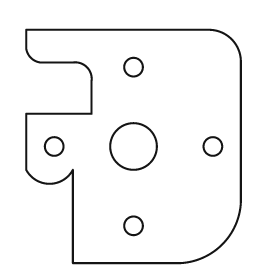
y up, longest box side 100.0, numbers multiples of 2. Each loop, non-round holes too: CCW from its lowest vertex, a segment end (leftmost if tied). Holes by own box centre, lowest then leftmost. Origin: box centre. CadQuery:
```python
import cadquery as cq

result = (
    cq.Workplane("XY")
    .moveTo(-26.0, -50.0)
    .lineTo(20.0, -50.0)
    .threePointArc((38.0, -42.0), (46.0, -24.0))
    .lineTo(46.0, 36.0)
    .threePointArc((42.0, 46.0), (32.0, 50.0))
    .lineTo(-46.0, 50.0)
    .lineTo(-46.0, 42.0)
    .threePointArc((-44.0, 38.0), (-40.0, 36.0))
    .lineTo(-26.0, 36.0)
    .threePointArc((-20.0, 34.0), (-18.0, 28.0))
    .lineTo(-18.0, 14.0)
    .lineTo(-46.0, 14.0)
    .lineTo(-46.0, -10.0)
    .threePointArc((-36.0, -16.0), (-26.0, -10.0))
    .close()
    .moveTo(0.0, -34.0)
    .circle(4.0)
    .moveTo(-34.0, 0.0)
    .circle(4.0)
    .moveTo(0.0, 0.0)
    .circle(10.0)
    .moveTo(34.0, 0.0)
    .circle(4.0)
    .moveTo(0.0, 34.0)
    .circle(4.0)
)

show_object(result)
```